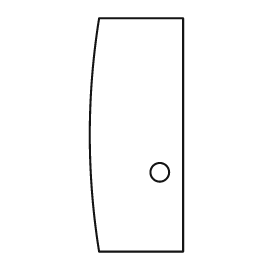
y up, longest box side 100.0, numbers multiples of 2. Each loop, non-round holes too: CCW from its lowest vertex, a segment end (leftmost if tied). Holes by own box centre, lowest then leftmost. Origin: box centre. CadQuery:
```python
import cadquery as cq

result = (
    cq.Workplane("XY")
    .moveTo(-16.0, -50.0)
    .lineTo(20.0, -50.0)
    .lineTo(20.0, 50.0)
    .lineTo(-16.0, 50.0)
    .threePointArc((-20.0, 0.0), (-16.0, -50.0))
    .close()
    .moveTo(10.0, -16.0)
    .circle(4.0)
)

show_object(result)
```